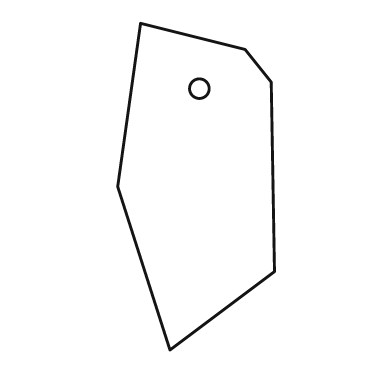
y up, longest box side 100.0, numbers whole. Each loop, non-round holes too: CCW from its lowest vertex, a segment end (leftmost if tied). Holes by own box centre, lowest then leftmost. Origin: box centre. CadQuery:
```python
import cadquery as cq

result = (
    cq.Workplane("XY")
    .moveTo(-8.0, -50.0)
    .lineTo(24.0, -26.0)
    .lineTo(23.0, 32.0)
    .lineTo(15.0, 42.0)
    .lineTo(-17.0, 50.0)
    .lineTo(-24.0, 0.0)
    .close()
    .moveTo(1.0, 30.0)
    .circle(3.0)
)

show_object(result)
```